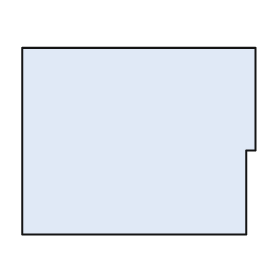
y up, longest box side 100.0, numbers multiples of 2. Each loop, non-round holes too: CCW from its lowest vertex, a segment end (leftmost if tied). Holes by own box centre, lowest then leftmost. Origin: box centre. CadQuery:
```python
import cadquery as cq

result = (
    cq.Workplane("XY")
    .moveTo(-50.0, -40.0)
    .lineTo(46.0, -40.0)
    .lineTo(46.0, -4.0)
    .lineTo(50.0, -4.0)
    .lineTo(50.0, 40.0)
    .lineTo(-50.0, 40.0)
    .close()
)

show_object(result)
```